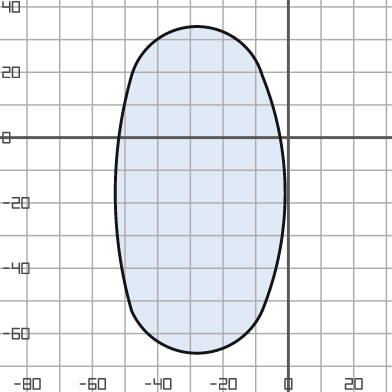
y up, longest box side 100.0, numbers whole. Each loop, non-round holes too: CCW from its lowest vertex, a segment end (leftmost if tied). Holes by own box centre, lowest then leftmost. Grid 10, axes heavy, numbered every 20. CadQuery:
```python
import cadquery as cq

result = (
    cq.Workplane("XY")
    .moveTo(-48.0, -53.0)
    .threePointArc((-28.0, -66.0), (-8.0, -53.0))
    .threePointArc((-1.0, -17.0), (-8.0, 19.0))
    .threePointArc((-28.0, 34.0), (-48.0, 19.0))
    .threePointArc((-53.0, -17.0), (-48.0, -53.0))
    .close()
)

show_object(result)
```